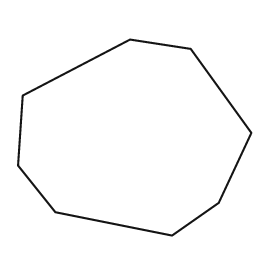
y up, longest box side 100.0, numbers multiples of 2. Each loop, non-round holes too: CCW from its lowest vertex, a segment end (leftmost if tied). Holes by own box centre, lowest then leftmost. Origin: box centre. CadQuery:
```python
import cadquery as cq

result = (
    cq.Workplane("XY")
    .moveTo(16.0, -42.0)
    .lineTo(36.0, -28.0)
    .lineTo(50.0, 2.0)
    .lineTo(24.0, 38.0)
    .lineTo(-2.0, 42.0)
    .lineTo(-48.0, 18.0)
    .lineTo(-50.0, -12.0)
    .lineTo(-34.0, -32.0)
    .close()
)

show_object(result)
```